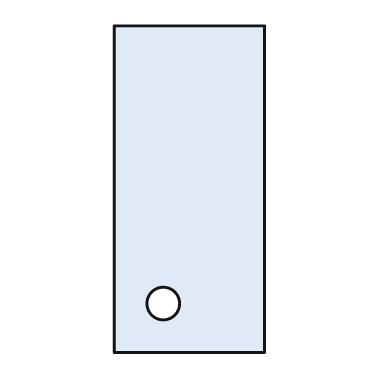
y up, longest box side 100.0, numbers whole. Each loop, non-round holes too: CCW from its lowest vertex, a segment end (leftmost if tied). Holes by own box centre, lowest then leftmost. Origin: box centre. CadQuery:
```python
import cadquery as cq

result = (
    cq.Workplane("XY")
    .moveTo(-23.0, -50.0)
    .lineTo(23.0, -50.0)
    .lineTo(23.0, 50.0)
    .lineTo(-23.0, 50.0)
    .close()
    .moveTo(-8.0, -35.0)
    .circle(5.0)
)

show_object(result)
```